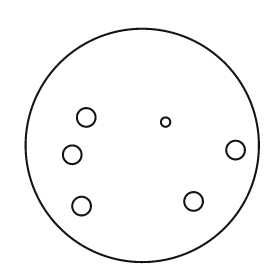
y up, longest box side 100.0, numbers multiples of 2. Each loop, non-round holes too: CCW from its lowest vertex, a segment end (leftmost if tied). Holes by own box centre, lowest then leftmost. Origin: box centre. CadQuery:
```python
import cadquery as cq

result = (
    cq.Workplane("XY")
    .moveTo(0.0, 0.0)
    .circle(50.0)
    .moveTo(-26.0, -26.0)
    .circle(4.0)
    .moveTo(22.0, -24.0)
    .circle(4.0)
    .moveTo(-30.0, -4.0)
    .circle(4.0)
    .moveTo(40.0, -2.0)
    .circle(4.0)
    .moveTo(10.0, 10.0)
    .circle(2.0)
    .moveTo(-24.0, 12.0)
    .circle(4.0)
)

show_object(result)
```